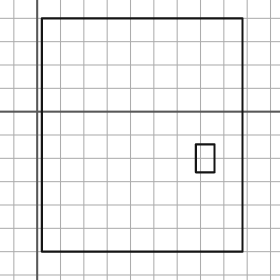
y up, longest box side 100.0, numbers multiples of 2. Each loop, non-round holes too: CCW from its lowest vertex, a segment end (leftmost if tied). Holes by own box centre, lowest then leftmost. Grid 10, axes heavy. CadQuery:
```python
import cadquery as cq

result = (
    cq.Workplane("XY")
    .moveTo(2.0, -60.0)
    .lineTo(88.0, -60.0)
    .lineTo(88.0, 40.0)
    .lineTo(2.0, 40.0)
    .close()
    .moveTo(68.0, -26.0)
    .lineTo(76.0, -26.0)
    .lineTo(76.0, -14.0)
    .lineTo(68.0, -14.0)
    .close()
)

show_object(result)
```